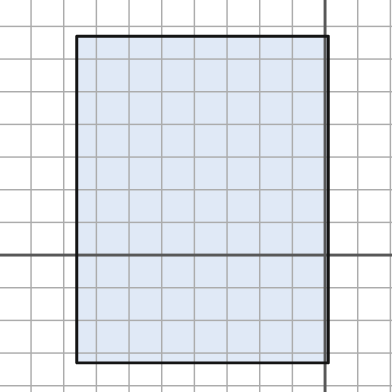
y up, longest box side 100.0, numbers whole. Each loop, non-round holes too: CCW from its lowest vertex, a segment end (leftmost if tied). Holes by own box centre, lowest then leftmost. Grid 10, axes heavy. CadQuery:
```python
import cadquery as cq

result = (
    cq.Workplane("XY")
    .moveTo(-76.0, -33.0)
    .lineTo(1.0, -33.0)
    .lineTo(1.0, 67.0)
    .lineTo(-76.0, 67.0)
    .close()
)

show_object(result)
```